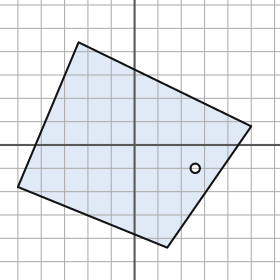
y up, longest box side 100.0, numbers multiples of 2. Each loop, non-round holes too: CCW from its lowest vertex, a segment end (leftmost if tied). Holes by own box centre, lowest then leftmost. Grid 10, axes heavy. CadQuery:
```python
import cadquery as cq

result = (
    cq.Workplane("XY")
    .moveTo(14.0, -44.0)
    .lineTo(50.0, 8.0)
    .lineTo(-24.0, 44.0)
    .lineTo(-50.0, -18.0)
    .close()
    .moveTo(26.0, -10.0)
    .circle(2.0)
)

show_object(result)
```